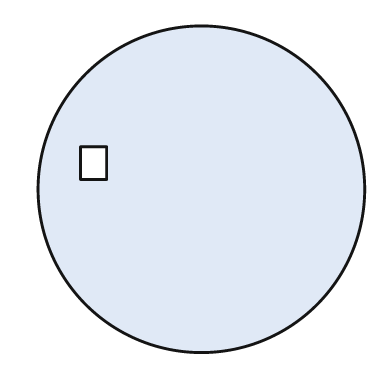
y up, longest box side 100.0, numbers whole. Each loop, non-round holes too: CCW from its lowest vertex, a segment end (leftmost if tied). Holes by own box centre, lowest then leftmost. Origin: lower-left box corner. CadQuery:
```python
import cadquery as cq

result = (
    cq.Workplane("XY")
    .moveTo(50.0, 50.0)
    .circle(50.0)
    .moveTo(13.0, 53.0)
    .lineTo(21.0, 53.0)
    .lineTo(21.0, 63.0)
    .lineTo(13.0, 63.0)
    .close()
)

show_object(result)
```